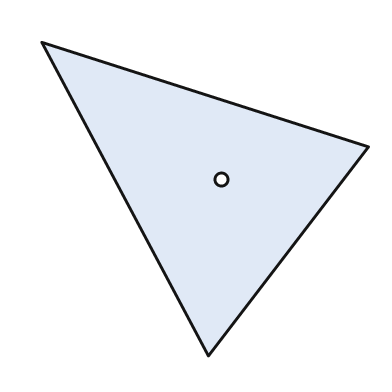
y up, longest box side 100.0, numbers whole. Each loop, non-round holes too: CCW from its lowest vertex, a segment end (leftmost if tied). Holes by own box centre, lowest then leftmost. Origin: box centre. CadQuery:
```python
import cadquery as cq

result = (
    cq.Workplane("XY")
    .moveTo(1.0, -48.0)
    .lineTo(50.0, 16.0)
    .lineTo(-50.0, 48.0)
    .close()
    .moveTo(5.0, 6.0)
    .circle(2.0)
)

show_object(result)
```